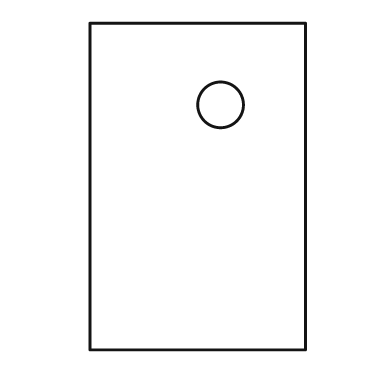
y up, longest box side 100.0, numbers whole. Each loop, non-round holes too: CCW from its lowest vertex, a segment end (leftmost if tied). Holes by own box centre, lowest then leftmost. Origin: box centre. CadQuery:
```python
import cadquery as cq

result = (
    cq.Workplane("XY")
    .moveTo(-33.0, -50.0)
    .lineTo(33.0, -50.0)
    .lineTo(33.0, 50.0)
    .lineTo(-33.0, 50.0)
    .close()
    .moveTo(7.0, 25.0)
    .circle(7.0)
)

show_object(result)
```